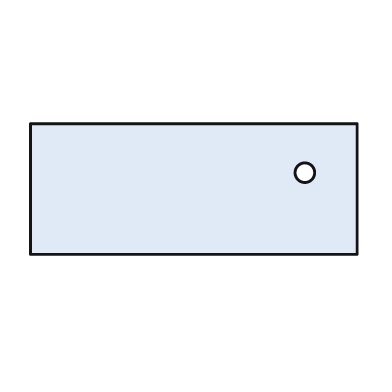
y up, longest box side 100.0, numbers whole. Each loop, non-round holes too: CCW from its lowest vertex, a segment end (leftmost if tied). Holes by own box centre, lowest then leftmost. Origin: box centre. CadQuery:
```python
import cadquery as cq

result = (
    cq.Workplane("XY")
    .moveTo(-50.0, -20.0)
    .lineTo(50.0, -20.0)
    .lineTo(50.0, 20.0)
    .lineTo(-50.0, 20.0)
    .close()
    .moveTo(34.0, 5.0)
    .circle(3.0)
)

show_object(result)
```